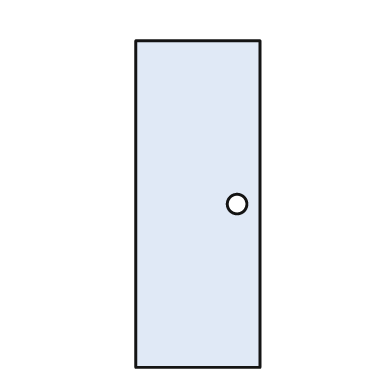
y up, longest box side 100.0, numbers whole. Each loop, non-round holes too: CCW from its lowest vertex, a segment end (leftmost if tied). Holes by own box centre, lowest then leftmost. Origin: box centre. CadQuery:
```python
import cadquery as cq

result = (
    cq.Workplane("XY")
    .moveTo(-19.0, -50.0)
    .lineTo(19.0, -50.0)
    .lineTo(19.0, 50.0)
    .lineTo(-19.0, 50.0)
    .close()
    .moveTo(12.0, 0.0)
    .circle(3.0)
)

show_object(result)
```